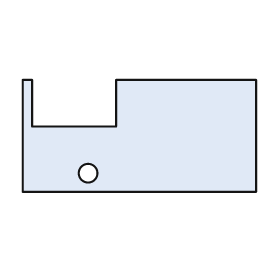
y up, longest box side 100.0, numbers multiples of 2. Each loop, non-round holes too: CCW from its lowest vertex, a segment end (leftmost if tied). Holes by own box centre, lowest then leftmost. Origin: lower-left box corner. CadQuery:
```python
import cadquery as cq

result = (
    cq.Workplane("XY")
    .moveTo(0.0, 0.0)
    .lineTo(100.0, 0.0)
    .lineTo(100.0, 48.0)
    .lineTo(40.0, 48.0)
    .lineTo(40.0, 28.0)
    .lineTo(4.0, 28.0)
    .lineTo(4.0, 48.0)
    .lineTo(0.0, 48.0)
    .close()
    .moveTo(28.0, 8.0)
    .circle(4.0)
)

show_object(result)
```